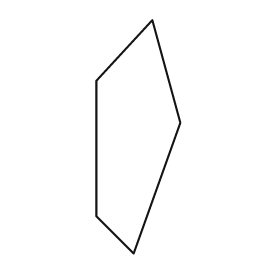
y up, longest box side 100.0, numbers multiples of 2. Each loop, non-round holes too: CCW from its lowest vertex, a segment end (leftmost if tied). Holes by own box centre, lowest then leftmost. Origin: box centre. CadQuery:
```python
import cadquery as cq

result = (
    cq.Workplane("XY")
    .moveTo(-2.0, -50.0)
    .lineTo(18.0, 6.0)
    .lineTo(6.0, 50.0)
    .lineTo(-18.0, 24.0)
    .lineTo(-18.0, -34.0)
    .close()
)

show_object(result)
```